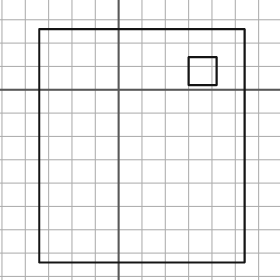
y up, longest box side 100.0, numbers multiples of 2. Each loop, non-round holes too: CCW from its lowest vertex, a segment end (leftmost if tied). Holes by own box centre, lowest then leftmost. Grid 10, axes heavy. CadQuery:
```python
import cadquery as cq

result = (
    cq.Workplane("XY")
    .moveTo(-34.0, -74.0)
    .lineTo(54.0, -74.0)
    .lineTo(54.0, 26.0)
    .lineTo(-34.0, 26.0)
    .close()
    .moveTo(30.0, 2.0)
    .lineTo(42.0, 2.0)
    .lineTo(42.0, 14.0)
    .lineTo(30.0, 14.0)
    .close()
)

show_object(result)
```